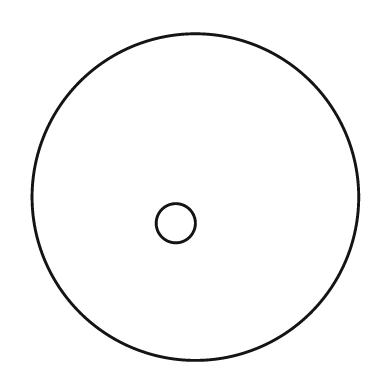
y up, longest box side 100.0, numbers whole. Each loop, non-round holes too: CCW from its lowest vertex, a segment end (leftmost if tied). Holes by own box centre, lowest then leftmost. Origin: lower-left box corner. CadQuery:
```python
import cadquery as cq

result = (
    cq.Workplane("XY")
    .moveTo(50.0, 50.0)
    .circle(50.0)
    .moveTo(44.0, 42.0)
    .circle(6.0)
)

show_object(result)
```